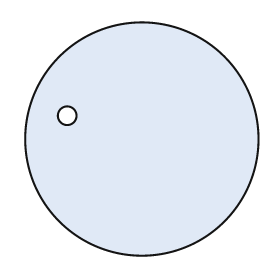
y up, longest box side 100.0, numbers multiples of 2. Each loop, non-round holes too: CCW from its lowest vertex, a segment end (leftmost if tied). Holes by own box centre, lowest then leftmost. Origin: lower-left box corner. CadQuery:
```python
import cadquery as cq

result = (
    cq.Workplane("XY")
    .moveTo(50.0, 50.0)
    .circle(50.0)
    .moveTo(18.0, 60.0)
    .circle(4.0)
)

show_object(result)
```